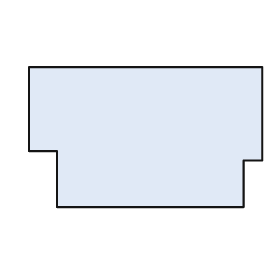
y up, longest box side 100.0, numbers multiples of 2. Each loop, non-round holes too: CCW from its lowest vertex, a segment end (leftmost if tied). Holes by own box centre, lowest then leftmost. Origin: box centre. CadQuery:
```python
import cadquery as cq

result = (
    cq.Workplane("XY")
    .moveTo(-38.0, -30.0)
    .lineTo(42.0, -30.0)
    .lineTo(42.0, -10.0)
    .lineTo(50.0, -10.0)
    .lineTo(50.0, 30.0)
    .lineTo(-50.0, 30.0)
    .lineTo(-50.0, -6.0)
    .lineTo(-38.0, -6.0)
    .close()
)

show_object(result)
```